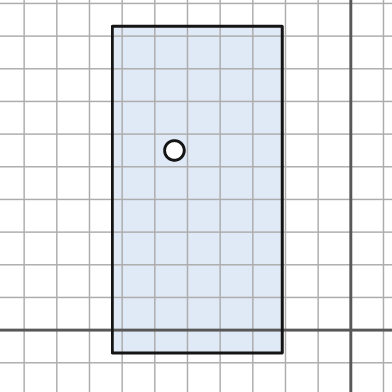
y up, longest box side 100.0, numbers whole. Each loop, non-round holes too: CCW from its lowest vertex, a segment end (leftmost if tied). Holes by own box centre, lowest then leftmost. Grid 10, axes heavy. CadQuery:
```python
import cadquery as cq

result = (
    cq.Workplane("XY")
    .moveTo(-73.0, -7.0)
    .lineTo(-21.0, -7.0)
    .lineTo(-21.0, 93.0)
    .lineTo(-73.0, 93.0)
    .close()
    .moveTo(-54.0, 55.0)
    .circle(3.0)
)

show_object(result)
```